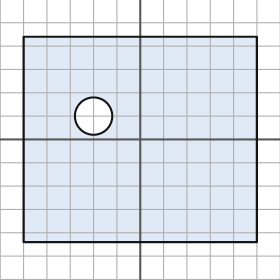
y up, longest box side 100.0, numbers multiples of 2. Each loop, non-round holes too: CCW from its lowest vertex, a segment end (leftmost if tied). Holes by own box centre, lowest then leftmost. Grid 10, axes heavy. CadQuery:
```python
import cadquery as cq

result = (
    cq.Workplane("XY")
    .moveTo(-50.0, -44.0)
    .lineTo(50.0, -44.0)
    .lineTo(50.0, 44.0)
    .lineTo(-50.0, 44.0)
    .close()
    .moveTo(-20.0, 10.0)
    .circle(8.0)
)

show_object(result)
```